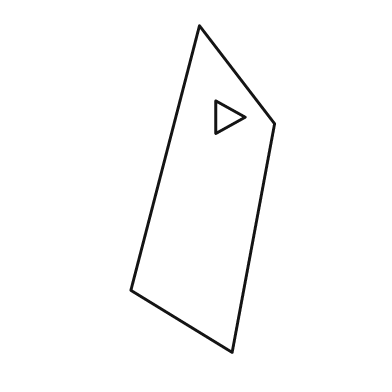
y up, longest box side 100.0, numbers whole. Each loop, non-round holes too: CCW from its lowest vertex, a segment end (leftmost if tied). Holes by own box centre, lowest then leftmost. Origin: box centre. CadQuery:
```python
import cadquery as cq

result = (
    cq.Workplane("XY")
    .moveTo(9.0, -50.0)
    .lineTo(22.0, 20.0)
    .lineTo(-1.0, 50.0)
    .lineTo(-22.0, -31.0)
    .close()
    .moveTo(4.0, 17.0)
    .lineTo(13.0, 22.0)
    .lineTo(4.0, 27.0)
    .close()
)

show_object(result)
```